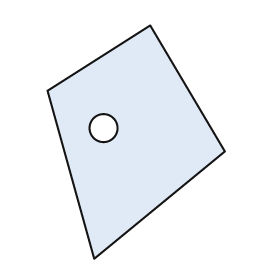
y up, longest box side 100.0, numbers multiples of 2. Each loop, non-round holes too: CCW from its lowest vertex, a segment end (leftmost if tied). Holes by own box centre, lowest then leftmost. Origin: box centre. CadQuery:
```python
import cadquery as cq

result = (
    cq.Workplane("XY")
    .moveTo(-18.0, -50.0)
    .lineTo(38.0, -4.0)
    .lineTo(6.0, 50.0)
    .lineTo(-38.0, 22.0)
    .close()
    .moveTo(-14.0, 6.0)
    .circle(6.0)
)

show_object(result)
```